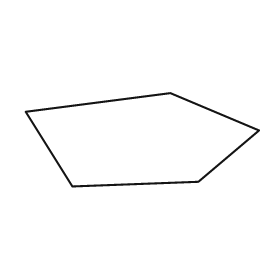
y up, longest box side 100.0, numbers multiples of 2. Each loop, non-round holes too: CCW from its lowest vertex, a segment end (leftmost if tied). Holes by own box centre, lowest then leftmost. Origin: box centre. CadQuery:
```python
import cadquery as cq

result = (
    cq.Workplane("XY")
    .moveTo(-30.0, -20.0)
    .lineTo(24.0, -18.0)
    .lineTo(50.0, 4.0)
    .lineTo(12.0, 20.0)
    .lineTo(-50.0, 12.0)
    .close()
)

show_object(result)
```